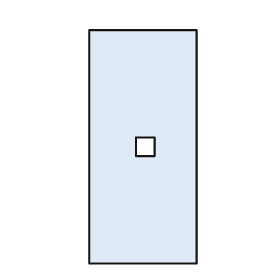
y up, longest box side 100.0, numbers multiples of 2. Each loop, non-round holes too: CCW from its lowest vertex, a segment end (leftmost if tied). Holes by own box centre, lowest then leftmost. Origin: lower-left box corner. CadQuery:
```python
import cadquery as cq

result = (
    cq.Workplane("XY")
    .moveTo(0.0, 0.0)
    .lineTo(46.0, 0.0)
    .lineTo(46.0, 100.0)
    .lineTo(0.0, 100.0)
    .close()
    .moveTo(20.0, 46.0)
    .lineTo(28.0, 46.0)
    .lineTo(28.0, 54.0)
    .lineTo(20.0, 54.0)
    .close()
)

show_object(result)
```